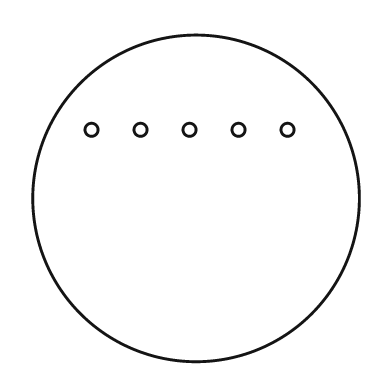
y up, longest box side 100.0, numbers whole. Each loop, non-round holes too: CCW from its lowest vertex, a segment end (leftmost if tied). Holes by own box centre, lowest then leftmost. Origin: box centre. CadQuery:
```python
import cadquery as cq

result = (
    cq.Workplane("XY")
    .moveTo(0.0, 0.0)
    .circle(50.0)
    .moveTo(-32.0, 21.0)
    .circle(2.0)
    .moveTo(-17.0, 21.0)
    .circle(2.0)
    .moveTo(-2.0, 21.0)
    .circle(2.0)
    .moveTo(13.0, 21.0)
    .circle(2.0)
    .moveTo(28.0, 21.0)
    .circle(2.0)
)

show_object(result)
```